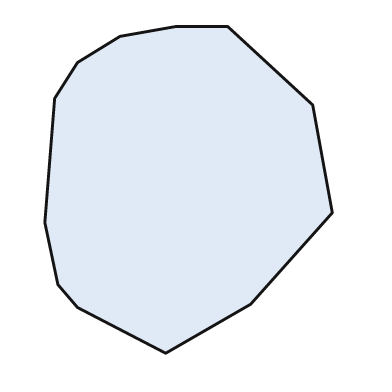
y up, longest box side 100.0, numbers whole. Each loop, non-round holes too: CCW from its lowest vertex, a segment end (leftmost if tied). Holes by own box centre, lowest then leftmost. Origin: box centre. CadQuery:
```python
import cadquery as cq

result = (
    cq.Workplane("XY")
    .moveTo(-7.0, -50.0)
    .lineTo(19.0, -35.0)
    .lineTo(44.0, -7.0)
    .lineTo(38.0, 26.0)
    .lineTo(12.0, 50.0)
    .lineTo(-4.0, 50.0)
    .lineTo(-21.0, 47.0)
    .lineTo(-34.0, 39.0)
    .lineTo(-41.0, 28.0)
    .lineTo(-44.0, -10.0)
    .lineTo(-40.0, -29.0)
    .lineTo(-34.0, -36.0)
    .close()
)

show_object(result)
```